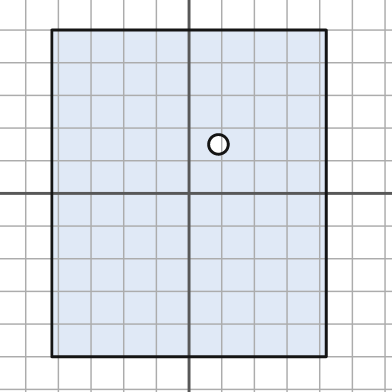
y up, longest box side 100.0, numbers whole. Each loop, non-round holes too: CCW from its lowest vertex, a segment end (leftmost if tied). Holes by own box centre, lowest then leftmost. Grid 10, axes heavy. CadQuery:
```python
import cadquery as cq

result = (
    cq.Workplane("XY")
    .moveTo(-42.0, -50.0)
    .lineTo(42.0, -50.0)
    .lineTo(42.0, 50.0)
    .lineTo(-42.0, 50.0)
    .close()
    .moveTo(9.0, 15.0)
    .circle(3.0)
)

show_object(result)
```